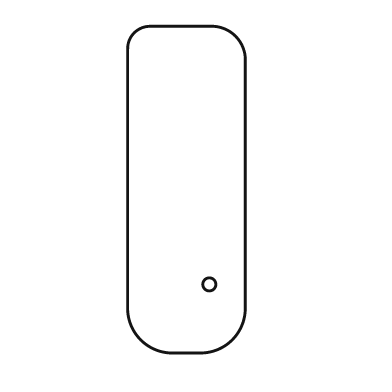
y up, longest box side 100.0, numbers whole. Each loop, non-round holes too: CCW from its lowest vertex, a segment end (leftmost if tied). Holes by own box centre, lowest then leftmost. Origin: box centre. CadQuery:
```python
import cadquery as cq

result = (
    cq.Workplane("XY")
    .moveTo(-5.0, -50.0)
    .lineTo(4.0, -50.0)
    .threePointArc((14.0, -46.0), (18.0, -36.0))
    .lineTo(18.0, 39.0)
    .threePointArc((15.0, 47.0), (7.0, 50.0))
    .lineTo(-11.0, 50.0)
    .threePointArc((-16.0, 48.0), (-18.0, 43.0))
    .lineTo(-18.0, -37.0)
    .threePointArc((-14.0, -46.0), (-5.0, -50.0))
    .close()
    .moveTo(7.0, -29.0)
    .circle(2.0)
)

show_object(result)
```